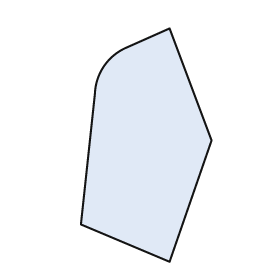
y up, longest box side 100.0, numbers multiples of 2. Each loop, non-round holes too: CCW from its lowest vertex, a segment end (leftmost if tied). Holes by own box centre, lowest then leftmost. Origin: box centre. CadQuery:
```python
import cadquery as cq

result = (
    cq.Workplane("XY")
    .moveTo(10.0, -50.0)
    .lineTo(28.0, 2.0)
    .lineTo(10.0, 50.0)
    .lineTo(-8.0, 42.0)
    .threePointArc((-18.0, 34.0), (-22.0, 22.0))
    .lineTo(-28.0, -34.0)
    .close()
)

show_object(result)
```